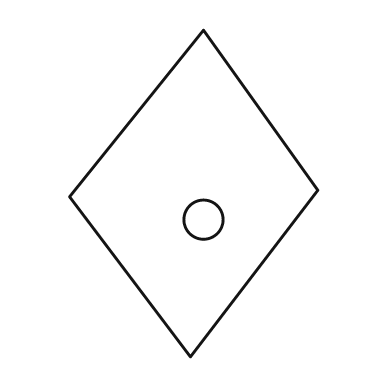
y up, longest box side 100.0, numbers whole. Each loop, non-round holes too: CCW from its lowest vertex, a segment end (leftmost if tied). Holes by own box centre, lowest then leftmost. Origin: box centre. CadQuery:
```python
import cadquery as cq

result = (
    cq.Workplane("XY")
    .moveTo(-1.0, -50.0)
    .lineTo(38.0, 1.0)
    .lineTo(3.0, 50.0)
    .lineTo(-38.0, -1.0)
    .close()
    .moveTo(3.0, -8.0)
    .circle(6.0)
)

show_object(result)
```